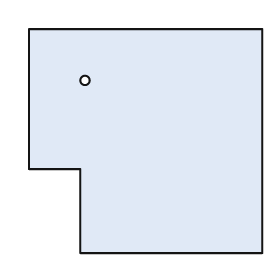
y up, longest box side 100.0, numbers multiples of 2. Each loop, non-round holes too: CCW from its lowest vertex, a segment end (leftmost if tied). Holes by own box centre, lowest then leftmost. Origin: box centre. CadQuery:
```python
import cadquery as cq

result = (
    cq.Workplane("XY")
    .moveTo(-28.0, -48.0)
    .lineTo(50.0, -48.0)
    .lineTo(50.0, 48.0)
    .lineTo(-50.0, 48.0)
    .lineTo(-50.0, -12.0)
    .lineTo(-28.0, -12.0)
    .close()
    .moveTo(-26.0, 26.0)
    .circle(2.0)
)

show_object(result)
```